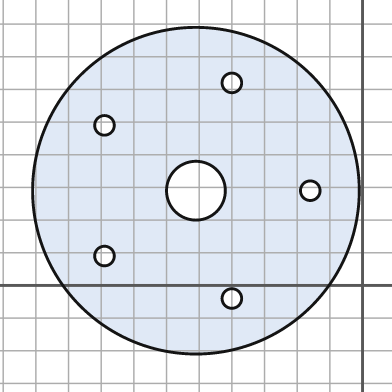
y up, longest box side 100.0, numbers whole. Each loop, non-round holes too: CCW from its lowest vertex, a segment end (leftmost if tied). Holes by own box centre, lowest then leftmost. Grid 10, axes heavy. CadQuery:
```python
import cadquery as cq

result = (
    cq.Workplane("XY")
    .moveTo(-51.0, 29.0)
    .circle(50.0)
    .moveTo(-40.0, -4.0)
    .circle(3.0)
    .moveTo(-79.0, 9.0)
    .circle(3.0)
    .moveTo(-51.0, 29.0)
    .circle(9.0)
    .moveTo(-16.0, 29.0)
    .circle(3.0)
    .moveTo(-79.0, 49.0)
    .circle(3.0)
    .moveTo(-40.0, 62.0)
    .circle(3.0)
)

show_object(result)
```